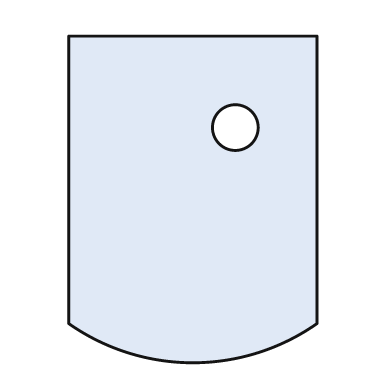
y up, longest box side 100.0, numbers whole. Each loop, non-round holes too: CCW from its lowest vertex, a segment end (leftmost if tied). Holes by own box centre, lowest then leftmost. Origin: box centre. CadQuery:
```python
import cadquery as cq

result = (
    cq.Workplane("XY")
    .moveTo(-38.0, -38.0)
    .threePointArc((0.0, -50.0), (38.0, -38.0))
    .lineTo(38.0, 50.0)
    .lineTo(-38.0, 50.0)
    .close()
    .moveTo(13.0, 22.0)
    .circle(7.0)
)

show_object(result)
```